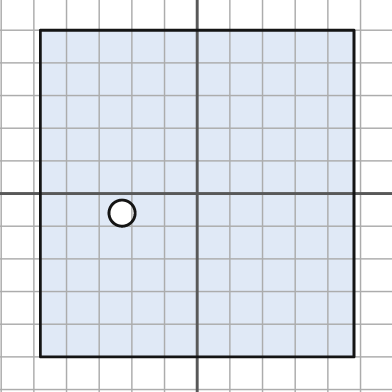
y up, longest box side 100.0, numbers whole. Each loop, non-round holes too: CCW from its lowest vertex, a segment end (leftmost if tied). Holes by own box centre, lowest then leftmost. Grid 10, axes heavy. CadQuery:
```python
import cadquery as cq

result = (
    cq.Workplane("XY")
    .moveTo(-48.0, -50.0)
    .lineTo(48.0, -50.0)
    .lineTo(48.0, 50.0)
    .lineTo(-48.0, 50.0)
    .close()
    .moveTo(-23.0, -6.0)
    .circle(4.0)
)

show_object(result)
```